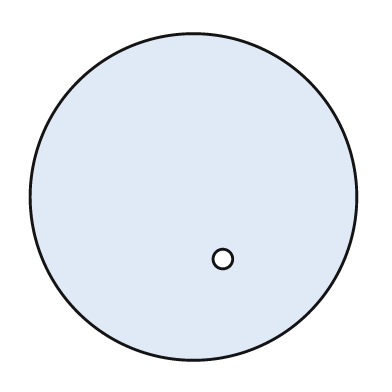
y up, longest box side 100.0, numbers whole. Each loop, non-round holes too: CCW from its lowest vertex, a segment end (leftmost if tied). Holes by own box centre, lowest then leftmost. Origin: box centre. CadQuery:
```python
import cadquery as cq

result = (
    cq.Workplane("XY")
    .moveTo(0.0, 0.0)
    .circle(50.0)
    .moveTo(9.0, -19.0)
    .circle(3.0)
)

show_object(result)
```